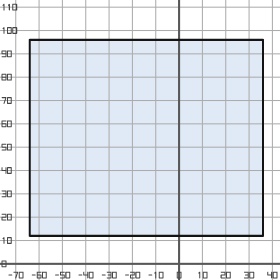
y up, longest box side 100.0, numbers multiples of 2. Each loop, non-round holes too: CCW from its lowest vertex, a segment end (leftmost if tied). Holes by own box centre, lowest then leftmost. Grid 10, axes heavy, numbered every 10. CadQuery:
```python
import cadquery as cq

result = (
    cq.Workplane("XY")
    .moveTo(-64.0, 12.0)
    .lineTo(36.0, 12.0)
    .lineTo(36.0, 96.0)
    .lineTo(-64.0, 96.0)
    .close()
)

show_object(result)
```